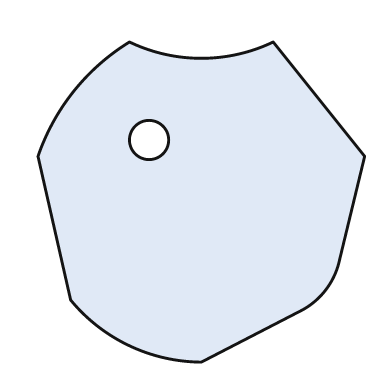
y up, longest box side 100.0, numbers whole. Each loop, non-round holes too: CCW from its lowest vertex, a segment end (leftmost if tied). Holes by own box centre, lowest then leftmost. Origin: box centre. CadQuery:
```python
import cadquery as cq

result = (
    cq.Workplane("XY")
    .moveTo(0.0, -49.0)
    .lineTo(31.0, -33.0)
    .threePointArc((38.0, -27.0), (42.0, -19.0))
    .lineTo(50.0, 14.0)
    .lineTo(22.0, 49.0)
    .threePointArc((0.0, 44.0), (-22.0, 49.0))
    .threePointArc((-39.0, 34.0), (-50.0, 14.0))
    .lineTo(-40.0, -30.0)
    .threePointArc((-22.0, -44.0), (0.0, -49.0))
    .close()
    .moveTo(-16.0, 19.0)
    .circle(6.0)
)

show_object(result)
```